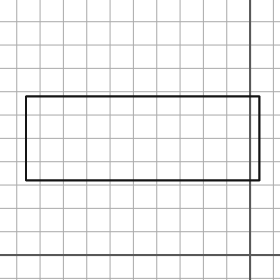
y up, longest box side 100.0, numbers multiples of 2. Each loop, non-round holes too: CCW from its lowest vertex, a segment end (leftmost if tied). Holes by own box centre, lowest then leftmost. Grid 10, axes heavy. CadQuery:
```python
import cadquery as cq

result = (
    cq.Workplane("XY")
    .moveTo(-96.0, 32.0)
    .lineTo(4.0, 32.0)
    .lineTo(4.0, 68.0)
    .lineTo(-96.0, 68.0)
    .close()
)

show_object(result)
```